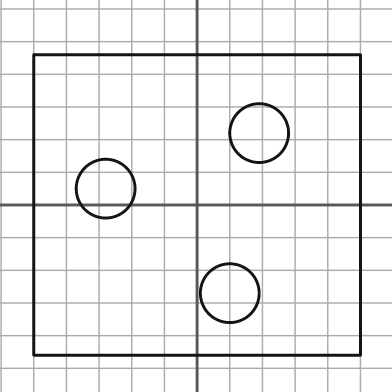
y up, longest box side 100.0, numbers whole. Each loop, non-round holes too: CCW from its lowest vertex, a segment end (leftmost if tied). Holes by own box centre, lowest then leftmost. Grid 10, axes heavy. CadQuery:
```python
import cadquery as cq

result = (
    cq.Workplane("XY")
    .moveTo(-50.0, -46.0)
    .lineTo(50.0, -46.0)
    .lineTo(50.0, 46.0)
    .lineTo(-50.0, 46.0)
    .close()
    .moveTo(10.0, -27.0)
    .circle(9.0)
    .moveTo(-28.0, 5.0)
    .circle(9.0)
    .moveTo(19.0, 22.0)
    .circle(9.0)
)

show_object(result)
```